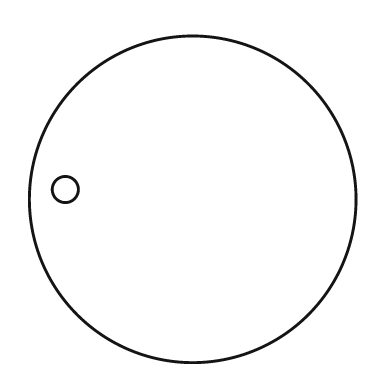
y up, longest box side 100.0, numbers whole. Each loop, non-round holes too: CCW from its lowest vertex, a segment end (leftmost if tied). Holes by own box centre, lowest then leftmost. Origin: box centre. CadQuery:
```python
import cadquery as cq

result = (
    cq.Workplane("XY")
    .moveTo(0.0, 0.0)
    .circle(50.0)
    .moveTo(-39.0, 3.0)
    .circle(4.0)
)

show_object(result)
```